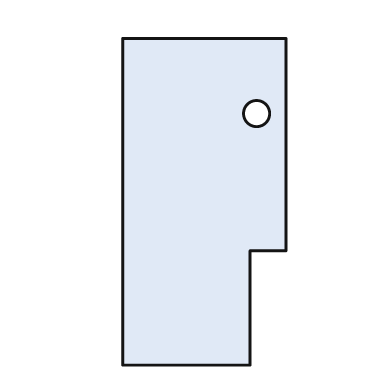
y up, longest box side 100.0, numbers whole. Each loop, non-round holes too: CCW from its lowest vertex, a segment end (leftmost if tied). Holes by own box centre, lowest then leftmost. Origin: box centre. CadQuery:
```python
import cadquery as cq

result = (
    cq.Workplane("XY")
    .moveTo(-25.0, -50.0)
    .lineTo(14.0, -50.0)
    .lineTo(14.0, -15.0)
    .lineTo(25.0, -15.0)
    .lineTo(25.0, 50.0)
    .lineTo(-25.0, 50.0)
    .close()
    .moveTo(16.0, 27.0)
    .circle(4.0)
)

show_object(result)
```